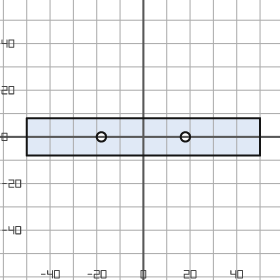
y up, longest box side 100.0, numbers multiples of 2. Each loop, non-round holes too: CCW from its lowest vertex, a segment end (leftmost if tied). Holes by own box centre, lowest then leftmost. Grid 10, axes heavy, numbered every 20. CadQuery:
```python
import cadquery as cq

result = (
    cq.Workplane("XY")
    .moveTo(-50.0, -8.0)
    .lineTo(50.0, -8.0)
    .lineTo(50.0, 8.0)
    .lineTo(-50.0, 8.0)
    .close()
    .moveTo(-18.0, 0.0)
    .circle(2.0)
    .moveTo(18.0, 0.0)
    .circle(2.0)
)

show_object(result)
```